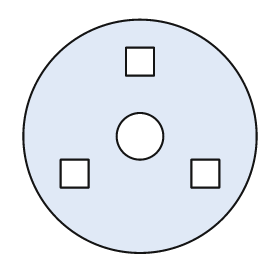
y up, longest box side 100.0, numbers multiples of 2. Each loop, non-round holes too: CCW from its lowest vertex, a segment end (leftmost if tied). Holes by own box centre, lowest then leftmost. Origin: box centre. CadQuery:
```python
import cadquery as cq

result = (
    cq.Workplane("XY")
    .moveTo(0.0, 0.0)
    .circle(50.0)
    .moveTo(-34.0, -22.0)
    .lineTo(-22.0, -22.0)
    .lineTo(-22.0, -10.0)
    .lineTo(-34.0, -10.0)
    .close()
    .moveTo(22.0, -22.0)
    .lineTo(34.0, -22.0)
    .lineTo(34.0, -10.0)
    .lineTo(22.0, -10.0)
    .close()
    .moveTo(0.0, 0.0)
    .circle(10.0)
    .moveTo(-6.0, 26.0)
    .lineTo(6.0, 26.0)
    .lineTo(6.0, 38.0)
    .lineTo(-6.0, 38.0)
    .close()
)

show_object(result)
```